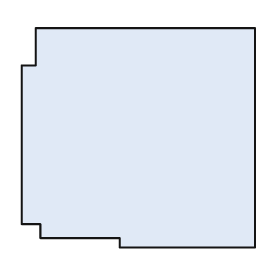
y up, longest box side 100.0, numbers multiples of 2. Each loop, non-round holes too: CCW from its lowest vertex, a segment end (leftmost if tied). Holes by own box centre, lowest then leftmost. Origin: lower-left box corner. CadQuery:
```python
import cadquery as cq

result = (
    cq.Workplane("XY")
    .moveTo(42.0, 0.0)
    .lineTo(100.0, 0.0)
    .lineTo(100.0, 94.0)
    .lineTo(6.0, 94.0)
    .lineTo(6.0, 78.0)
    .lineTo(0.0, 78.0)
    .lineTo(0.0, 10.0)
    .lineTo(8.0, 10.0)
    .lineTo(8.0, 4.0)
    .lineTo(42.0, 4.0)
    .close()
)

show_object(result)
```